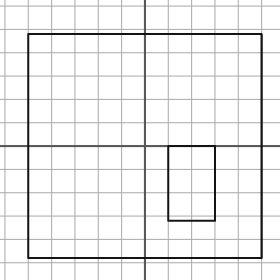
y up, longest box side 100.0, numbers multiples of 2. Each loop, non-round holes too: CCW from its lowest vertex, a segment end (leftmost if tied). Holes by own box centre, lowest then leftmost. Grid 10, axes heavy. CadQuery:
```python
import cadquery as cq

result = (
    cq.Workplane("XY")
    .moveTo(-50.0, -48.0)
    .lineTo(50.0, -48.0)
    .lineTo(50.0, 48.0)
    .lineTo(-50.0, 48.0)
    .close()
    .moveTo(10.0, -32.0)
    .lineTo(30.0, -32.0)
    .lineTo(30.0, 0.0)
    .lineTo(10.0, 0.0)
    .close()
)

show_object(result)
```